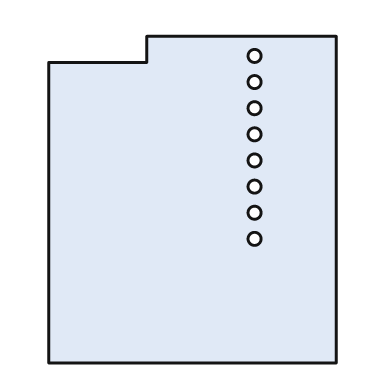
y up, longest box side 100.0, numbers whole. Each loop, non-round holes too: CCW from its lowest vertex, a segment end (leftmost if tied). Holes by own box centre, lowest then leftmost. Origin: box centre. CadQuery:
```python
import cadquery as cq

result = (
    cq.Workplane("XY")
    .moveTo(-44.0, -50.0)
    .lineTo(44.0, -50.0)
    .lineTo(44.0, 50.0)
    .lineTo(-14.0, 50.0)
    .lineTo(-14.0, 42.0)
    .lineTo(-44.0, 42.0)
    .close()
    .moveTo(19.0, -12.0)
    .circle(2.0)
    .moveTo(19.0, -4.0)
    .circle(2.0)
    .moveTo(19.0, 4.0)
    .circle(2.0)
    .moveTo(19.0, 12.0)
    .circle(2.0)
    .moveTo(19.0, 20.0)
    .circle(2.0)
    .moveTo(19.0, 28.0)
    .circle(2.0)
    .moveTo(19.0, 36.0)
    .circle(2.0)
    .moveTo(19.0, 44.0)
    .circle(2.0)
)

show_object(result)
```